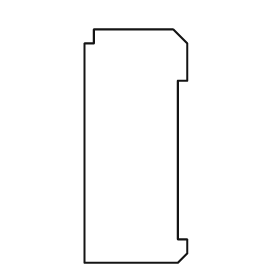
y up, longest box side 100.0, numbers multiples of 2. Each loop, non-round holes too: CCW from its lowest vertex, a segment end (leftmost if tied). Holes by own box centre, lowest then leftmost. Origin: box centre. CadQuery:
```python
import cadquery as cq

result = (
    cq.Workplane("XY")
    .moveTo(-22.0, -50.0)
    .lineTo(18.0, -50.0)
    .lineTo(22.0, -46.0)
    .lineTo(22.0, -40.0)
    .lineTo(18.0, -40.0)
    .lineTo(18.0, 28.0)
    .lineTo(22.0, 28.0)
    .lineTo(22.0, 44.0)
    .lineTo(16.0, 50.0)
    .lineTo(-18.0, 50.0)
    .lineTo(-18.0, 44.0)
    .lineTo(-22.0, 44.0)
    .close()
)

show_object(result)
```